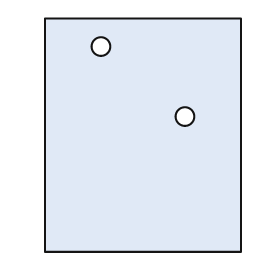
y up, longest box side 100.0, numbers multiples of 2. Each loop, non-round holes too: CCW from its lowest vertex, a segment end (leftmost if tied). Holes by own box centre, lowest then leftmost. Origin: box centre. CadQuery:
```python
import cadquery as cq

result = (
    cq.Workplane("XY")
    .moveTo(-42.0, -50.0)
    .lineTo(42.0, -50.0)
    .lineTo(42.0, 50.0)
    .lineTo(-42.0, 50.0)
    .close()
    .moveTo(18.0, 8.0)
    .circle(4.0)
    .moveTo(-18.0, 38.0)
    .circle(4.0)
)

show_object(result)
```